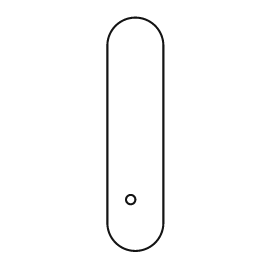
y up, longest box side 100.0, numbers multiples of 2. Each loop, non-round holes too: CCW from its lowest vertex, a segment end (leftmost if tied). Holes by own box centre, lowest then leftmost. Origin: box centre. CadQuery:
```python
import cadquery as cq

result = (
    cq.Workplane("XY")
    .moveTo(-12.0, -38.0)
    .threePointArc((0.0, -50.0), (12.0, -38.0))
    .lineTo(12.0, 38.0)
    .threePointArc((0.0, 50.0), (-12.0, 38.0))
    .close()
    .moveTo(-2.0, -28.0)
    .circle(2.0)
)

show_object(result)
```